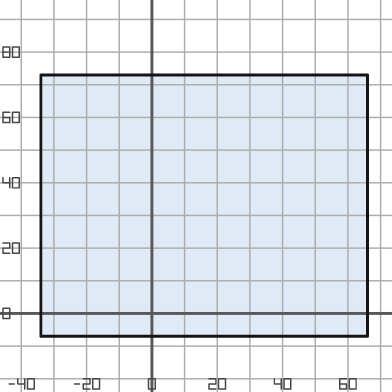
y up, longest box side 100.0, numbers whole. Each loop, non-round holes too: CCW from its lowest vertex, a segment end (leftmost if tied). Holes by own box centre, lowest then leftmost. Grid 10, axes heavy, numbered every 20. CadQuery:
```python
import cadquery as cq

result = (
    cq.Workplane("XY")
    .moveTo(-34.0, -7.0)
    .lineTo(66.0, -7.0)
    .lineTo(66.0, 73.0)
    .lineTo(-34.0, 73.0)
    .close()
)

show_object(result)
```